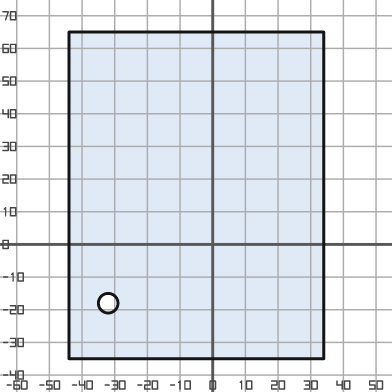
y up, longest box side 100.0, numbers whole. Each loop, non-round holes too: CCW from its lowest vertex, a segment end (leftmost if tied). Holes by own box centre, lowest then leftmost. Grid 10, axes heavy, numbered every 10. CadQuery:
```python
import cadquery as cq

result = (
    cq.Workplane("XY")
    .moveTo(-44.0, -35.0)
    .lineTo(34.0, -35.0)
    .lineTo(34.0, 65.0)
    .lineTo(-44.0, 65.0)
    .close()
    .moveTo(-32.0, -18.0)
    .circle(3.0)
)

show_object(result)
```